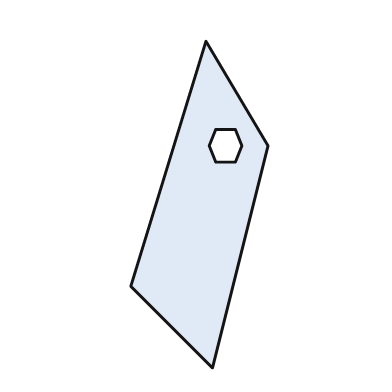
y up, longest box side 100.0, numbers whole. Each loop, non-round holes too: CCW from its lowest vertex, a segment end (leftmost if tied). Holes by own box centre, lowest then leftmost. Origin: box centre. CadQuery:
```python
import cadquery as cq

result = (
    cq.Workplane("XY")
    .moveTo(4.0, -50.0)
    .lineTo(21.0, 18.0)
    .lineTo(2.0, 50.0)
    .lineTo(-21.0, -25.0)
    .close()
    .moveTo(5.0, 13.0)
    .lineTo(11.0, 13.0)
    .lineTo(13.0, 18.0)
    .lineTo(11.0, 23.0)
    .lineTo(5.0, 23.0)
    .lineTo(3.0, 18.0)
    .close()
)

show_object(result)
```